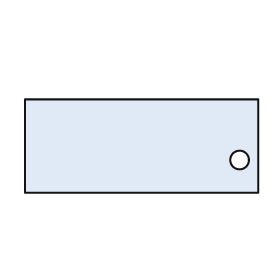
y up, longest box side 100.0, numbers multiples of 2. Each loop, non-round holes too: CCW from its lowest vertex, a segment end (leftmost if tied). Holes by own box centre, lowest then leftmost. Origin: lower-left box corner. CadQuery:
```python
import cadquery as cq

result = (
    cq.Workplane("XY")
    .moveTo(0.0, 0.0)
    .lineTo(100.0, 0.0)
    .lineTo(100.0, 40.0)
    .lineTo(0.0, 40.0)
    .close()
    .moveTo(92.0, 14.0)
    .circle(4.0)
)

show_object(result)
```